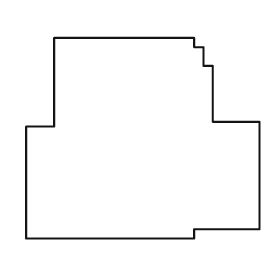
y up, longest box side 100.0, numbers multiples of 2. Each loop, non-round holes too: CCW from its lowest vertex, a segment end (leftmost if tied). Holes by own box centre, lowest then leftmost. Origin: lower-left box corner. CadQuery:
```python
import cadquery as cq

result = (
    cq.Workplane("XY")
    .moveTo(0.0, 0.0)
    .lineTo(72.0, 0.0)
    .lineTo(72.0, 4.0)
    .lineTo(100.0, 4.0)
    .lineTo(100.0, 50.0)
    .lineTo(80.0, 50.0)
    .lineTo(80.0, 74.0)
    .lineTo(76.0, 74.0)
    .lineTo(76.0, 82.0)
    .lineTo(72.0, 82.0)
    .lineTo(72.0, 86.0)
    .lineTo(12.0, 86.0)
    .lineTo(12.0, 48.0)
    .lineTo(0.0, 48.0)
    .close()
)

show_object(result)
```